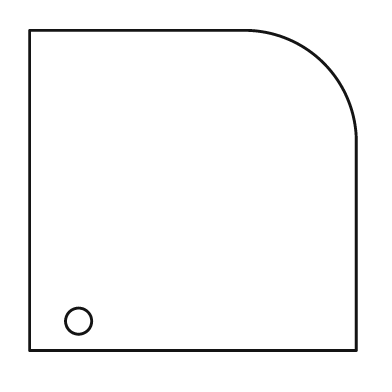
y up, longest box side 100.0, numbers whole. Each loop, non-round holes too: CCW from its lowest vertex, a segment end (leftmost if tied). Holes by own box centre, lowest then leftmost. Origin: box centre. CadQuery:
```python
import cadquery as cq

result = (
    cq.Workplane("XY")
    .moveTo(-50.0, -49.0)
    .lineTo(50.0, -49.0)
    .lineTo(50.0, 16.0)
    .threePointArc((40.0, 39.0), (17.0, 49.0))
    .lineTo(-50.0, 49.0)
    .close()
    .moveTo(-35.0, -40.0)
    .circle(4.0)
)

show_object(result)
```